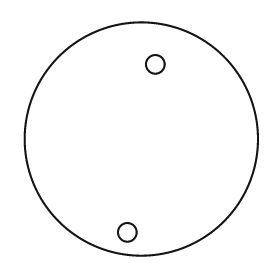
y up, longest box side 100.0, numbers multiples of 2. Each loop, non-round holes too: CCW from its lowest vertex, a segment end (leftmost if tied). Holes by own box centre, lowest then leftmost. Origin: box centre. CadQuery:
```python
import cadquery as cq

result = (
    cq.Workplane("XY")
    .moveTo(0.0, 0.0)
    .circle(50.0)
    .moveTo(-6.0, -40.0)
    .circle(4.0)
    .moveTo(6.0, 32.0)
    .circle(4.0)
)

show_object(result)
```